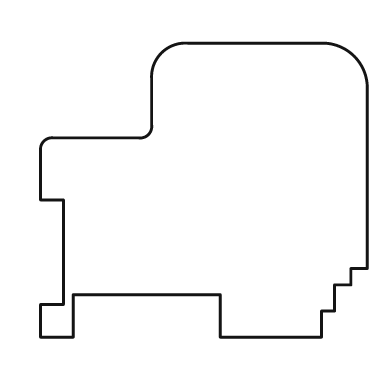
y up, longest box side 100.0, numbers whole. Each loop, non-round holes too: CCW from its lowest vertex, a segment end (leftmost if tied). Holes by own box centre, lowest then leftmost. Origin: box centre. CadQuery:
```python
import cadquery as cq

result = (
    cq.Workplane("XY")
    .moveTo(-50.0, -45.0)
    .lineTo(-40.0, -45.0)
    .lineTo(-40.0, -32.0)
    .lineTo(5.0, -32.0)
    .lineTo(5.0, -45.0)
    .lineTo(36.0, -45.0)
    .lineTo(36.0, -37.0)
    .lineTo(40.0, -37.0)
    .lineTo(40.0, -29.0)
    .lineTo(45.0, -29.0)
    .lineTo(45.0, -24.0)
    .lineTo(50.0, -24.0)
    .lineTo(50.0, 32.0)
    .threePointArc((46.0, 41.0), (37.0, 45.0))
    .lineTo(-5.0, 45.0)
    .threePointArc((-13.0, 42.0), (-16.0, 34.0))
    .lineTo(-16.0, 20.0)
    .threePointArc((-17.0, 17.0), (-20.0, 16.0))
    .lineTo(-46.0, 16.0)
    .threePointArc((-49.0, 15.0), (-50.0, 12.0))
    .lineTo(-50.0, -3.0)
    .lineTo(-43.0, -3.0)
    .lineTo(-43.0, -35.0)
    .lineTo(-50.0, -35.0)
    .close()
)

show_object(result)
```